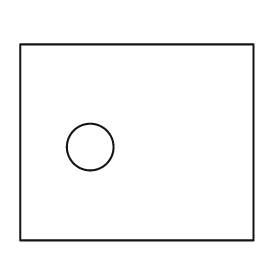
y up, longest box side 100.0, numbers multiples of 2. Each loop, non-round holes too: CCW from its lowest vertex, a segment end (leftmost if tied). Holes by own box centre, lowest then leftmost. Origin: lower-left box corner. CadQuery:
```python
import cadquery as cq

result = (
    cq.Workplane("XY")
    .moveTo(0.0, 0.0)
    .lineTo(100.0, 0.0)
    .lineTo(100.0, 84.0)
    .lineTo(0.0, 84.0)
    .close()
    .moveTo(30.0, 40.0)
    .circle(10.0)
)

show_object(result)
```